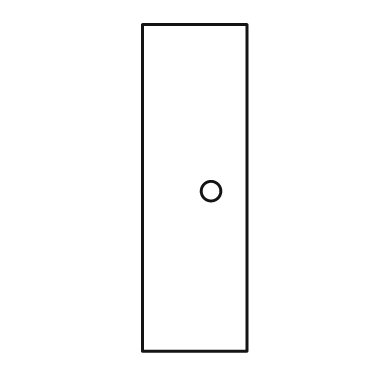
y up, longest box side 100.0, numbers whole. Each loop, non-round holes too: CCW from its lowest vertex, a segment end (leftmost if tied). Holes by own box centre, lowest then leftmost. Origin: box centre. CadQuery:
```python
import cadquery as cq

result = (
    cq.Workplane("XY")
    .moveTo(-16.0, -50.0)
    .lineTo(16.0, -50.0)
    .lineTo(16.0, 50.0)
    .lineTo(-16.0, 50.0)
    .close()
    .moveTo(5.0, -1.0)
    .circle(3.0)
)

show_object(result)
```